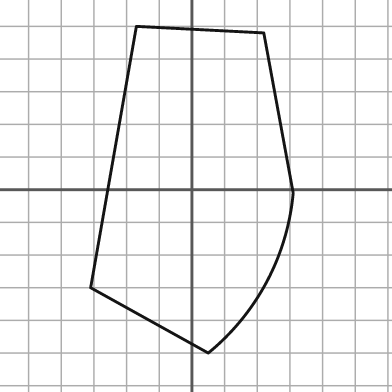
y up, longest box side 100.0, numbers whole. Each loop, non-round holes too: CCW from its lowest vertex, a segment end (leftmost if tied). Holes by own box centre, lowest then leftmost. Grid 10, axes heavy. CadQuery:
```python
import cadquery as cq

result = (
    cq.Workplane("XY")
    .moveTo(5.0, -50.0)
    .threePointArc((23.0, -28.0), (31.0, -1.0))
    .lineTo(22.0, 48.0)
    .lineTo(-17.0, 50.0)
    .lineTo(-31.0, -30.0)
    .close()
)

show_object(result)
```